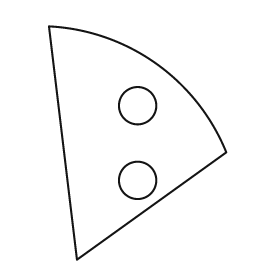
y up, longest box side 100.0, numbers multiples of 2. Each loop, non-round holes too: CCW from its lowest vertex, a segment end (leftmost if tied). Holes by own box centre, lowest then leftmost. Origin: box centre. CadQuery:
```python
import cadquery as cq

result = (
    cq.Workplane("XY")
    .moveTo(-26.0, -50.0)
    .lineTo(38.0, -4.0)
    .threePointArc((8.0, 34.0), (-38.0, 50.0))
    .close()
    .moveTo(0.0, -16.0)
    .circle(8.0)
    .moveTo(0.0, 16.0)
    .circle(8.0)
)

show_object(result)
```